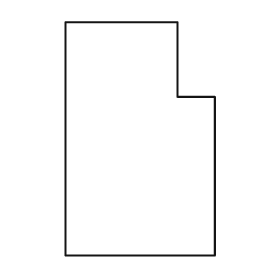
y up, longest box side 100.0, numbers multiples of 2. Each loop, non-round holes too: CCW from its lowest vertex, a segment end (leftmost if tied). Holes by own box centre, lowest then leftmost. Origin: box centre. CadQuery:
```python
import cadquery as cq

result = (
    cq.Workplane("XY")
    .moveTo(-32.0, -50.0)
    .lineTo(32.0, -50.0)
    .lineTo(32.0, 18.0)
    .lineTo(16.0, 18.0)
    .lineTo(16.0, 50.0)
    .lineTo(-32.0, 50.0)
    .close()
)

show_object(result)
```